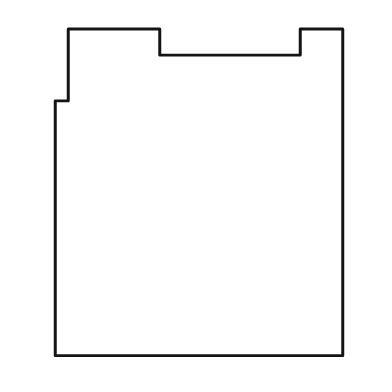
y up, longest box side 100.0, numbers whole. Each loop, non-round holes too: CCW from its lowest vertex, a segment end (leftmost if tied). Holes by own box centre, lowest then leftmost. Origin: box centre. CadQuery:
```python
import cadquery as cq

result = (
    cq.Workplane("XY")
    .moveTo(-44.0, -50.0)
    .lineTo(44.0, -50.0)
    .lineTo(44.0, 50.0)
    .lineTo(31.0, 50.0)
    .lineTo(31.0, 42.0)
    .lineTo(-12.0, 42.0)
    .lineTo(-12.0, 50.0)
    .lineTo(-40.0, 50.0)
    .lineTo(-40.0, 28.0)
    .lineTo(-44.0, 28.0)
    .close()
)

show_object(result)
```